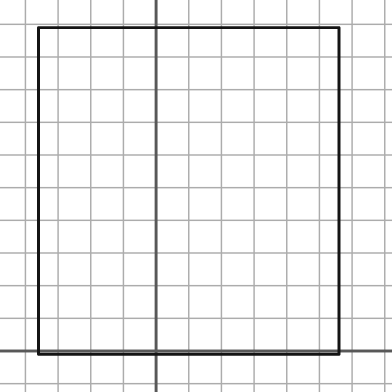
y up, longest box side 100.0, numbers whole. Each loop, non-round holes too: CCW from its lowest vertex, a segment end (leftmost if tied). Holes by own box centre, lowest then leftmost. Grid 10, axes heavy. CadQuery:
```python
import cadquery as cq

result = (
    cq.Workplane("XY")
    .moveTo(-36.0, -1.0)
    .lineTo(56.0, -1.0)
    .lineTo(56.0, 99.0)
    .lineTo(-36.0, 99.0)
    .close()
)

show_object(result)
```